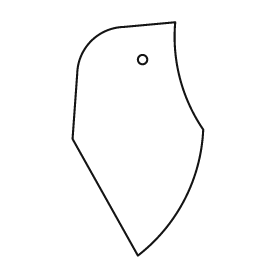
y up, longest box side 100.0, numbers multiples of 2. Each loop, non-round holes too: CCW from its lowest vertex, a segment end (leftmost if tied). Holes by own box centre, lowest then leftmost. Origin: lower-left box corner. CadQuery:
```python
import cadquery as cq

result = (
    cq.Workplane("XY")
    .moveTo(28.0, 0.0)
    .threePointArc((48.0, 24.0), (56.0, 54.0))
    .threePointArc((46.0, 76.0), (44.0, 100.0))
    .lineTo(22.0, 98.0)
    .threePointArc((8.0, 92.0), (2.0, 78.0))
    .lineTo(0.0, 50.0)
    .close()
    .moveTo(30.0, 84.0)
    .circle(2.0)
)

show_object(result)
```